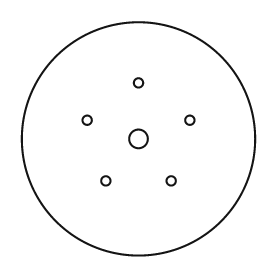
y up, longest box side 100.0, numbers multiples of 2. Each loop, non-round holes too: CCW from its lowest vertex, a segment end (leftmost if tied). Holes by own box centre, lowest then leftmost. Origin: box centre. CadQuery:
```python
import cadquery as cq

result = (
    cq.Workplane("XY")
    .moveTo(0.0, 0.0)
    .circle(50.0)
    .moveTo(-14.0, -18.0)
    .circle(2.0)
    .moveTo(14.0, -18.0)
    .circle(2.0)
    .moveTo(0.0, 0.0)
    .circle(4.0)
    .moveTo(-22.0, 8.0)
    .circle(2.0)
    .moveTo(22.0, 8.0)
    .circle(2.0)
    .moveTo(0.0, 24.0)
    .circle(2.0)
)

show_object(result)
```